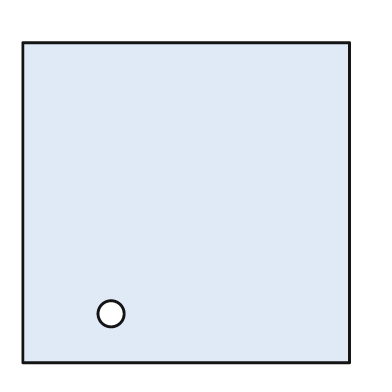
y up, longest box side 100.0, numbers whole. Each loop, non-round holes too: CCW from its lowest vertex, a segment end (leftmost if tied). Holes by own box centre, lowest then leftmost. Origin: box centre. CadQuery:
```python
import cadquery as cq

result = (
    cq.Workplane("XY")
    .moveTo(-50.0, -49.0)
    .lineTo(50.0, -49.0)
    .lineTo(50.0, 49.0)
    .lineTo(-50.0, 49.0)
    .close()
    .moveTo(-23.0, -34.0)
    .circle(4.0)
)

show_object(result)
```